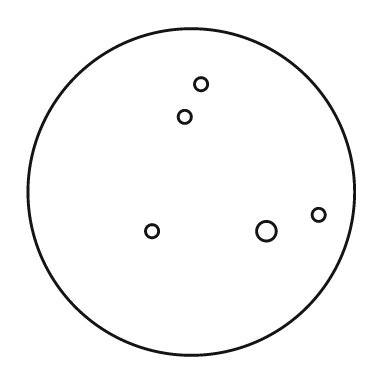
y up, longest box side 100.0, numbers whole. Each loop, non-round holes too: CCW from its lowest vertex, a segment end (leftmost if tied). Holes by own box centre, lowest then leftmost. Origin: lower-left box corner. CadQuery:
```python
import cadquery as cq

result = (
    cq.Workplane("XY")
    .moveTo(50.0, 50.0)
    .circle(50.0)
    .moveTo(38.0, 38.0)
    .circle(2.0)
    .moveTo(73.0, 38.0)
    .circle(3.0)
    .moveTo(89.0, 43.0)
    .circle(2.0)
    .moveTo(48.0, 73.0)
    .circle(2.0)
    .moveTo(53.0, 83.0)
    .circle(2.0)
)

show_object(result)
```